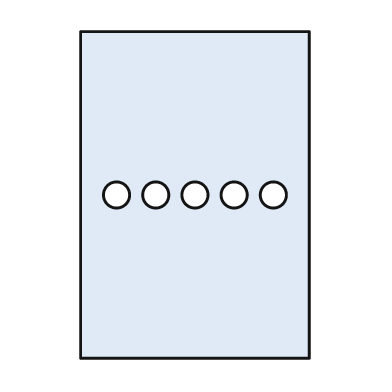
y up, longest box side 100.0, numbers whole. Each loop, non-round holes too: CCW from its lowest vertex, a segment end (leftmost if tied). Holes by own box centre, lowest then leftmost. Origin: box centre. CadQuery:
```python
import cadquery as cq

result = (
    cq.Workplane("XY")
    .moveTo(-35.0, -50.0)
    .lineTo(35.0, -50.0)
    .lineTo(35.0, 50.0)
    .lineTo(-35.0, 50.0)
    .close()
    .moveTo(-24.0, 0.0)
    .circle(4.0)
    .moveTo(-12.0, 0.0)
    .circle(4.0)
    .moveTo(0.0, 0.0)
    .circle(4.0)
    .moveTo(12.0, 0.0)
    .circle(4.0)
    .moveTo(24.0, 0.0)
    .circle(4.0)
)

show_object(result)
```